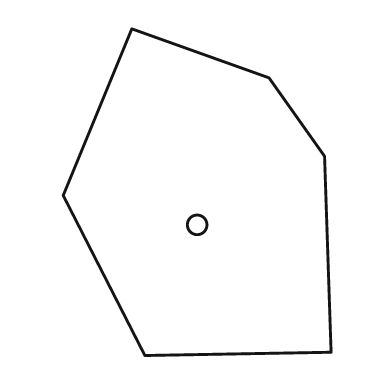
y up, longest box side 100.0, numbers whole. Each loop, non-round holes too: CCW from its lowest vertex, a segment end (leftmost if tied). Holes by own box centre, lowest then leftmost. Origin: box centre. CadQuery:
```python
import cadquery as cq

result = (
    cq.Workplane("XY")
    .moveTo(-16.0, -50.0)
    .lineTo(41.0, -49.0)
    .lineTo(39.0, 11.0)
    .lineTo(22.0, 35.0)
    .lineTo(-20.0, 50.0)
    .lineTo(-41.0, -1.0)
    .close()
    .moveTo(0.0, -10.0)
    .circle(3.0)
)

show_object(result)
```